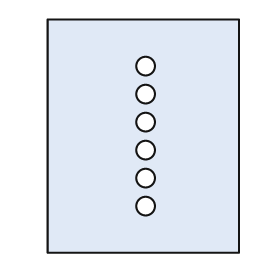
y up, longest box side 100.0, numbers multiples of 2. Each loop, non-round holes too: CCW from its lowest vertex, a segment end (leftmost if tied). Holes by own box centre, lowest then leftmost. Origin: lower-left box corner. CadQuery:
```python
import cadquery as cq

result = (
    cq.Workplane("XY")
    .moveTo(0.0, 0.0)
    .lineTo(82.0, 0.0)
    .lineTo(82.0, 100.0)
    .lineTo(0.0, 100.0)
    .close()
    .moveTo(42.0, 20.0)
    .circle(4.0)
    .moveTo(42.0, 32.0)
    .circle(4.0)
    .moveTo(42.0, 44.0)
    .circle(4.0)
    .moveTo(42.0, 56.0)
    .circle(4.0)
    .moveTo(42.0, 68.0)
    .circle(4.0)
    .moveTo(42.0, 80.0)
    .circle(4.0)
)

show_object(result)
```